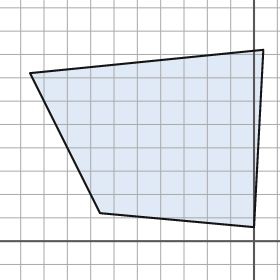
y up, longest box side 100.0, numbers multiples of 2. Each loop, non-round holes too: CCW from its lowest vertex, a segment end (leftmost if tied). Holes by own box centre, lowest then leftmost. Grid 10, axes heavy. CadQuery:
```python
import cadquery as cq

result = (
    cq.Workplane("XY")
    .moveTo(0.0, 6.0)
    .lineTo(4.0, 82.0)
    .lineTo(-96.0, 72.0)
    .lineTo(-66.0, 12.0)
    .close()
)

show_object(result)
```